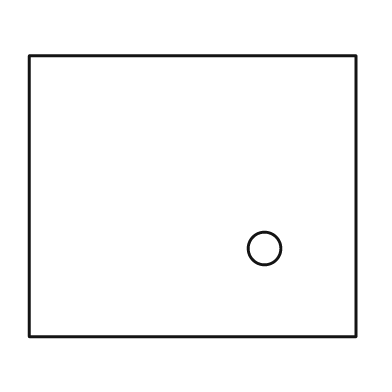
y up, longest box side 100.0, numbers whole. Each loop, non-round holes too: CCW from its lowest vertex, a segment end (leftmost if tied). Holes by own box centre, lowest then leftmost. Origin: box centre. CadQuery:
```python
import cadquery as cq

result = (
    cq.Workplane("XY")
    .moveTo(-50.0, -43.0)
    .lineTo(50.0, -43.0)
    .lineTo(50.0, 43.0)
    .lineTo(-50.0, 43.0)
    .close()
    .moveTo(22.0, -16.0)
    .circle(5.0)
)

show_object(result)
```